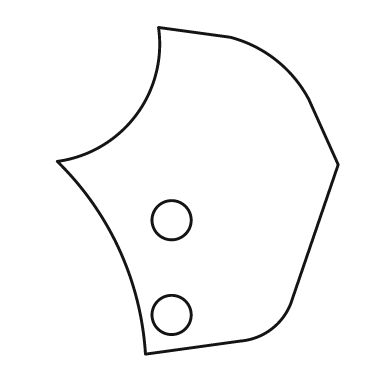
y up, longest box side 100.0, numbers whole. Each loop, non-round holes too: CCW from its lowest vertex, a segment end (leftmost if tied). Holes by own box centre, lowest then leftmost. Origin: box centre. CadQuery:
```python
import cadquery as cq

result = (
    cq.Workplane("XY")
    .moveTo(-16.0, -50.0)
    .lineTo(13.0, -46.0)
    .threePointArc((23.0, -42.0), (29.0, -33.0))
    .lineTo(43.0, 8.0)
    .lineTo(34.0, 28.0)
    .threePointArc((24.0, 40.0), (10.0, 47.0))
    .lineTo(-12.0, 50.0)
    .threePointArc((-19.0, 23.0), (-43.0, 9.0))
    .threePointArc((-24.0, -18.0), (-16.0, -50.0))
    .close()
    .moveTo(-8.0, -38.0)
    .circle(6.0)
    .moveTo(-8.0, -9.0)
    .circle(6.0)
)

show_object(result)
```